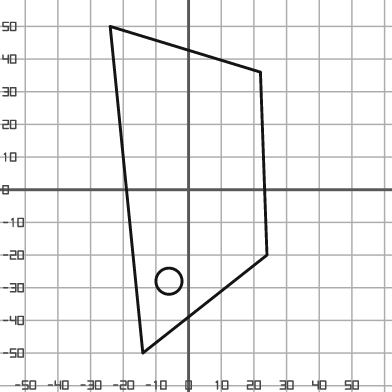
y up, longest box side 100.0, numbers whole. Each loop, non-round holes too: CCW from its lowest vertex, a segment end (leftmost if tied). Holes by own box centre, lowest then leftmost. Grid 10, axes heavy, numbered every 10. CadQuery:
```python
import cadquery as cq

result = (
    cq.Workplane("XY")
    .moveTo(-14.0, -50.0)
    .lineTo(24.0, -20.0)
    .lineTo(22.0, 36.0)
    .lineTo(-24.0, 50.0)
    .close()
    .moveTo(-6.0, -28.0)
    .circle(4.0)
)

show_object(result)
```